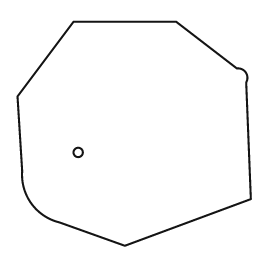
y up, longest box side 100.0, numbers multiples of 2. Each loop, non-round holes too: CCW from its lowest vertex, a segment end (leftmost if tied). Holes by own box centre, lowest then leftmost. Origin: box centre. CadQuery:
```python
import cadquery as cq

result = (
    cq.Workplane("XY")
    .moveTo(-4.0, -48.0)
    .lineTo(50.0, -28.0)
    .lineTo(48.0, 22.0)
    .threePointArc((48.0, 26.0), (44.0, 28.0))
    .lineTo(18.0, 48.0)
    .lineTo(-26.0, 48.0)
    .lineTo(-50.0, 16.0)
    .lineTo(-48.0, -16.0)
    .threePointArc((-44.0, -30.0), (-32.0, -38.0))
    .close()
    .moveTo(-24.0, -8.0)
    .circle(2.0)
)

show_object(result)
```